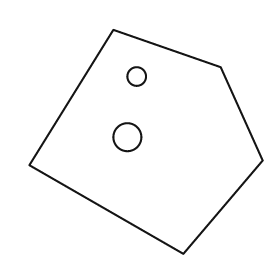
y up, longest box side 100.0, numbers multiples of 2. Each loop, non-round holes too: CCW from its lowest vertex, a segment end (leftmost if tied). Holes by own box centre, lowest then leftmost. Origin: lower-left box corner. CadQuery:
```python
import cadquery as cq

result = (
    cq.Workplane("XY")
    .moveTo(66.0, 0.0)
    .lineTo(100.0, 40.0)
    .lineTo(82.0, 80.0)
    .lineTo(36.0, 96.0)
    .lineTo(0.0, 38.0)
    .close()
    .moveTo(42.0, 50.0)
    .circle(6.0)
    .moveTo(46.0, 76.0)
    .circle(4.0)
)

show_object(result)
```